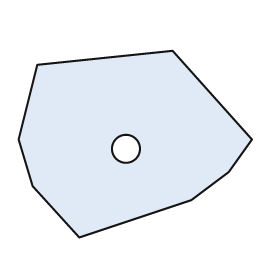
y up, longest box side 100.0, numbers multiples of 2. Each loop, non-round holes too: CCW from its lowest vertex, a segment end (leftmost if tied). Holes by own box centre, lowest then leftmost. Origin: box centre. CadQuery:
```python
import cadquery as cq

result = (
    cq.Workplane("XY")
    .moveTo(-24.0, -40.0)
    .lineTo(24.0, -24.0)
    .lineTo(40.0, -12.0)
    .lineTo(50.0, 2.0)
    .lineTo(16.0, 40.0)
    .lineTo(-42.0, 34.0)
    .lineTo(-50.0, 2.0)
    .lineTo(-44.0, -18.0)
    .close()
    .moveTo(-4.0, -2.0)
    .circle(6.0)
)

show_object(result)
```